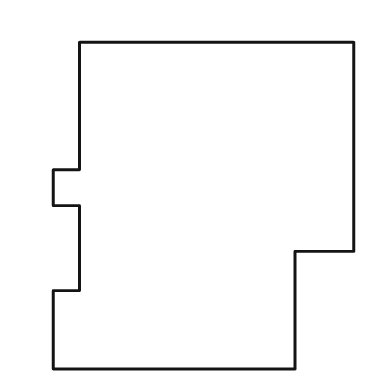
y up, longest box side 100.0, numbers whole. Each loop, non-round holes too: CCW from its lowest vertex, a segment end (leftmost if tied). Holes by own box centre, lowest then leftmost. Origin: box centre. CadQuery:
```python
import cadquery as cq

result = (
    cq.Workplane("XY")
    .moveTo(-46.0, -50.0)
    .lineTo(28.0, -50.0)
    .lineTo(28.0, -14.0)
    .lineTo(46.0, -14.0)
    .lineTo(46.0, 50.0)
    .lineTo(-38.0, 50.0)
    .lineTo(-38.0, 11.0)
    .lineTo(-46.0, 11.0)
    .lineTo(-46.0, 0.0)
    .lineTo(-38.0, 0.0)
    .lineTo(-38.0, -26.0)
    .lineTo(-46.0, -26.0)
    .close()
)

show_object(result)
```